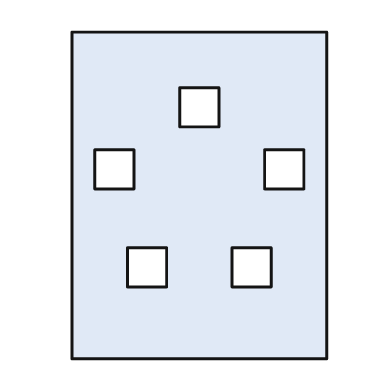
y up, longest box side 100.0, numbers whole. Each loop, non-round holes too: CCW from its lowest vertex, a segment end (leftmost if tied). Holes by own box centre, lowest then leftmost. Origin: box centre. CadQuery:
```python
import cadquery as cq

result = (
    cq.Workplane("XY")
    .moveTo(-39.0, -50.0)
    .lineTo(39.0, -50.0)
    .lineTo(39.0, 50.0)
    .lineTo(-39.0, 50.0)
    .close()
    .moveTo(-22.0, -28.0)
    .lineTo(-10.0, -28.0)
    .lineTo(-10.0, -16.0)
    .lineTo(-22.0, -16.0)
    .close()
    .moveTo(10.0, -28.0)
    .lineTo(22.0, -28.0)
    .lineTo(22.0, -16.0)
    .lineTo(10.0, -16.0)
    .close()
    .moveTo(-32.0, 2.0)
    .lineTo(-20.0, 2.0)
    .lineTo(-20.0, 14.0)
    .lineTo(-32.0, 14.0)
    .close()
    .moveTo(20.0, 2.0)
    .lineTo(32.0, 2.0)
    .lineTo(32.0, 14.0)
    .lineTo(20.0, 14.0)
    .close()
    .moveTo(-6.0, 21.0)
    .lineTo(6.0, 21.0)
    .lineTo(6.0, 33.0)
    .lineTo(-6.0, 33.0)
    .close()
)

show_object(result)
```